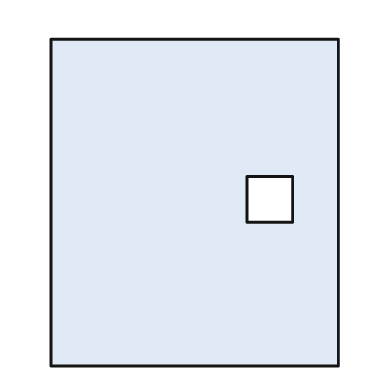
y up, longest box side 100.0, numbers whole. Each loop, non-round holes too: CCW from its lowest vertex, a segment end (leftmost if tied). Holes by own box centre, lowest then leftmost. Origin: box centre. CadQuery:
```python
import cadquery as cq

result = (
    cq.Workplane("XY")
    .moveTo(-44.0, -50.0)
    .lineTo(44.0, -50.0)
    .lineTo(44.0, 50.0)
    .lineTo(-44.0, 50.0)
    .close()
    .moveTo(16.0, -6.0)
    .lineTo(30.0, -6.0)
    .lineTo(30.0, 8.0)
    .lineTo(16.0, 8.0)
    .close()
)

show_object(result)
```